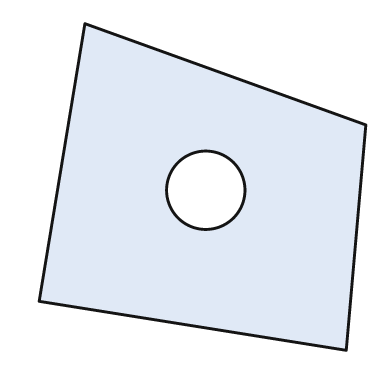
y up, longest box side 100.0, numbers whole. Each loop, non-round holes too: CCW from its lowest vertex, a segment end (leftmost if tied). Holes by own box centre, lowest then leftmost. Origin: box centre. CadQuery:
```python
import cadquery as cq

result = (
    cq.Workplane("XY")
    .moveTo(44.0, -50.0)
    .lineTo(50.0, 19.0)
    .lineTo(-36.0, 50.0)
    .lineTo(-50.0, -35.0)
    .close()
    .moveTo(1.0, -1.0)
    .circle(12.0)
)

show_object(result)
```